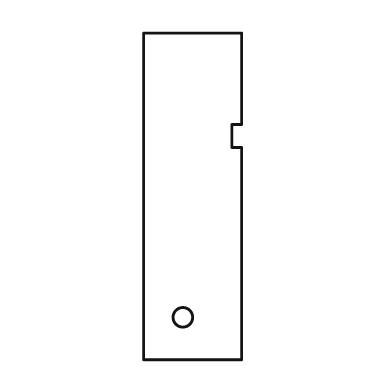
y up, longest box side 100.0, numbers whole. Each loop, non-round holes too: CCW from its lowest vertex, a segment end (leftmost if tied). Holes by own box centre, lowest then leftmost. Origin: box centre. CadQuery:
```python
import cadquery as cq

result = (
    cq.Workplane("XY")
    .moveTo(-15.0, -50.0)
    .lineTo(15.0, -50.0)
    .lineTo(15.0, 15.0)
    .lineTo(12.0, 15.0)
    .lineTo(12.0, 22.0)
    .lineTo(15.0, 22.0)
    .lineTo(15.0, 50.0)
    .lineTo(-15.0, 50.0)
    .close()
    .moveTo(-3.0, -37.0)
    .circle(3.0)
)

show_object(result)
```